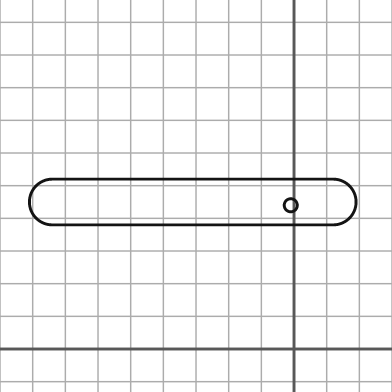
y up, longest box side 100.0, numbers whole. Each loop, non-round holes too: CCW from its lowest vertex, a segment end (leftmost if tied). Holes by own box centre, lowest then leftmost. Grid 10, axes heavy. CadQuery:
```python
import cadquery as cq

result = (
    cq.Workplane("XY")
    .moveTo(-74.0, 38.0)
    .lineTo(12.0, 38.0)
    .threePointArc((19.0, 45.0), (12.0, 52.0))
    .lineTo(-74.0, 52.0)
    .threePointArc((-81.0, 45.0), (-74.0, 38.0))
    .close()
    .moveTo(-1.0, 44.0)
    .circle(2.0)
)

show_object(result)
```